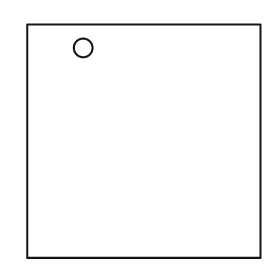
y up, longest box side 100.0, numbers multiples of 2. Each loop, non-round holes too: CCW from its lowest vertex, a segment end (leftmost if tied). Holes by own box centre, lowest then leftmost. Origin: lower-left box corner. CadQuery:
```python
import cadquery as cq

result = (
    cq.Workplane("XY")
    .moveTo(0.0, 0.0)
    .lineTo(100.0, 0.0)
    .lineTo(100.0, 100.0)
    .lineTo(0.0, 100.0)
    .close()
    .moveTo(24.0, 90.0)
    .circle(4.0)
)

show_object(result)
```